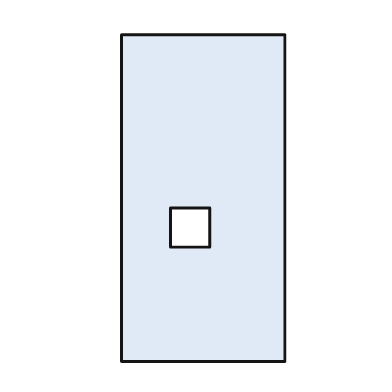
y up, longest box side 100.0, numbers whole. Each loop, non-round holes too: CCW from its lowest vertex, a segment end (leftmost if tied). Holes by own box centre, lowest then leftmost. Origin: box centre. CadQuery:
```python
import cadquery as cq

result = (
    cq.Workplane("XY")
    .moveTo(-25.0, -50.0)
    .lineTo(25.0, -50.0)
    .lineTo(25.0, 50.0)
    .lineTo(-25.0, 50.0)
    .close()
    .moveTo(-10.0, -15.0)
    .lineTo(2.0, -15.0)
    .lineTo(2.0, -3.0)
    .lineTo(-10.0, -3.0)
    .close()
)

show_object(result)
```